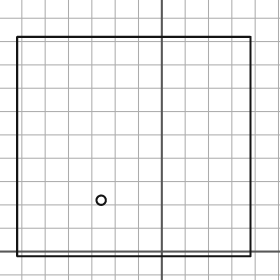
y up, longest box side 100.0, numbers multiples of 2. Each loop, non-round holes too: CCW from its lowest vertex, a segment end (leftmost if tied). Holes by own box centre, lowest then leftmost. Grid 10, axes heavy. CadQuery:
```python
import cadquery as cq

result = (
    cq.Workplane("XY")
    .moveTo(-62.0, -2.0)
    .lineTo(38.0, -2.0)
    .lineTo(38.0, 92.0)
    .lineTo(-62.0, 92.0)
    .close()
    .moveTo(-26.0, 22.0)
    .circle(2.0)
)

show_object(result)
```